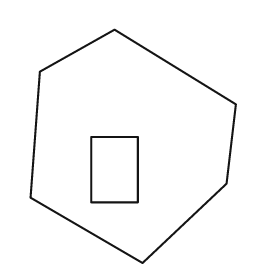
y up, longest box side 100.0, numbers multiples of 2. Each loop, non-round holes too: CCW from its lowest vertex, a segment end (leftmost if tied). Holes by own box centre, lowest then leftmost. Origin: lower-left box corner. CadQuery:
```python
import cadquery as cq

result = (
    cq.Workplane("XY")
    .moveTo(48.0, 0.0)
    .lineTo(84.0, 34.0)
    .lineTo(88.0, 68.0)
    .lineTo(36.0, 100.0)
    .lineTo(4.0, 82.0)
    .lineTo(0.0, 28.0)
    .close()
    .moveTo(26.0, 26.0)
    .lineTo(46.0, 26.0)
    .lineTo(46.0, 54.0)
    .lineTo(26.0, 54.0)
    .close()
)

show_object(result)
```